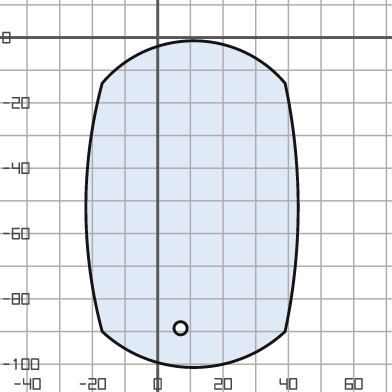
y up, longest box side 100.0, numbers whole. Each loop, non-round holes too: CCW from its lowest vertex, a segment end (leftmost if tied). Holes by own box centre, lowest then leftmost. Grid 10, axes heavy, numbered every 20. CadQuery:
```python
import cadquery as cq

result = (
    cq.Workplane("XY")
    .moveTo(-17.0, -90.0)
    .threePointArc((11.0, -101.0), (39.0, -90.0))
    .threePointArc((43.0, -52.0), (39.0, -14.0))
    .threePointArc((11.0, -1.0), (-17.0, -14.0))
    .threePointArc((-22.0, -52.0), (-17.0, -90.0))
    .close()
    .moveTo(7.0, -89.0)
    .circle(2.0)
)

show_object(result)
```